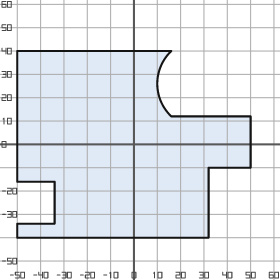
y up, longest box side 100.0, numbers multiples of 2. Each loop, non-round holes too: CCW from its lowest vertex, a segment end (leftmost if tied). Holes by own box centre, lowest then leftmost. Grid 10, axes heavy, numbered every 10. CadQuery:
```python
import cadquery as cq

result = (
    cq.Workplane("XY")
    .moveTo(-50.0, -40.0)
    .lineTo(32.0, -40.0)
    .lineTo(32.0, -10.0)
    .lineTo(50.0, -10.0)
    .lineTo(50.0, 12.0)
    .lineTo(16.0, 12.0)
    .threePointArc((10.0, 26.0), (16.0, 40.0))
    .lineTo(-50.0, 40.0)
    .lineTo(-50.0, -16.0)
    .lineTo(-34.0, -16.0)
    .lineTo(-34.0, -34.0)
    .lineTo(-50.0, -34.0)
    .close()
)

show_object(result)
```